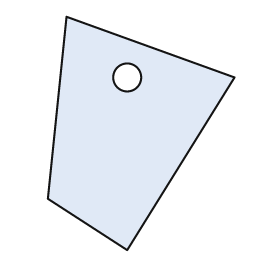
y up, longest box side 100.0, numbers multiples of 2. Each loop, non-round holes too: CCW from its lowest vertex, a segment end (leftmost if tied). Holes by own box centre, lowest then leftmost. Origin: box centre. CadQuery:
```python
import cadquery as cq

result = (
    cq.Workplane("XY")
    .moveTo(-6.0, -50.0)
    .lineTo(40.0, 24.0)
    .lineTo(-32.0, 50.0)
    .lineTo(-40.0, -28.0)
    .close()
    .moveTo(-6.0, 24.0)
    .circle(6.0)
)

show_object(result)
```